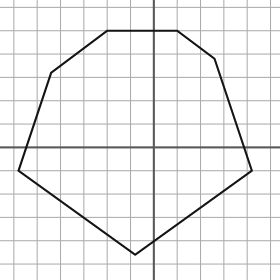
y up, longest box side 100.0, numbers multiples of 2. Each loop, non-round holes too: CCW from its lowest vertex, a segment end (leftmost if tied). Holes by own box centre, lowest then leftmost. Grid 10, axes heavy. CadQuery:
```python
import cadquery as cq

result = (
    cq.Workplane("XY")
    .moveTo(-8.0, -46.0)
    .lineTo(42.0, -10.0)
    .lineTo(26.0, 38.0)
    .lineTo(10.0, 50.0)
    .lineTo(-20.0, 50.0)
    .lineTo(-44.0, 32.0)
    .lineTo(-58.0, -10.0)
    .close()
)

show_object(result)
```